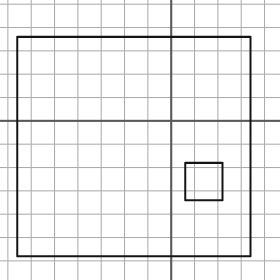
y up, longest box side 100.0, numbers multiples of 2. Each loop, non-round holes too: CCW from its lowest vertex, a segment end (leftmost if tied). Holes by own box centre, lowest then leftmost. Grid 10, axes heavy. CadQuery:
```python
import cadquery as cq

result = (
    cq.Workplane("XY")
    .moveTo(-66.0, -58.0)
    .lineTo(34.0, -58.0)
    .lineTo(34.0, 36.0)
    .lineTo(-66.0, 36.0)
    .close()
    .moveTo(6.0, -34.0)
    .lineTo(22.0, -34.0)
    .lineTo(22.0, -18.0)
    .lineTo(6.0, -18.0)
    .close()
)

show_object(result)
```